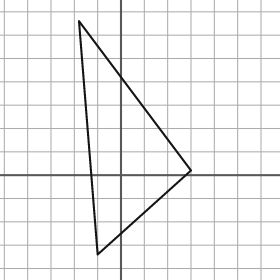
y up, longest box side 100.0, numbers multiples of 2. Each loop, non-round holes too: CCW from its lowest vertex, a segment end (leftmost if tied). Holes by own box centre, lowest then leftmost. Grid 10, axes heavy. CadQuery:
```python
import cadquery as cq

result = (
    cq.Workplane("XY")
    .moveTo(-10.0, -34.0)
    .lineTo(30.0, 2.0)
    .lineTo(-18.0, 66.0)
    .close()
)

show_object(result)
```